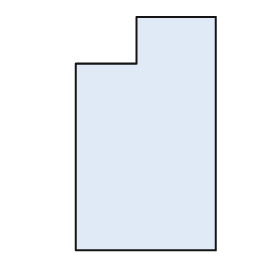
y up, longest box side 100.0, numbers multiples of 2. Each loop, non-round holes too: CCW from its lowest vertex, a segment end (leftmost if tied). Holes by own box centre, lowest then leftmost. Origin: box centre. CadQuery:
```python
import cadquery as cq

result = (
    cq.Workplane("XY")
    .moveTo(-30.0, -50.0)
    .lineTo(30.0, -50.0)
    .lineTo(30.0, 50.0)
    .lineTo(-4.0, 50.0)
    .lineTo(-4.0, 30.0)
    .lineTo(-30.0, 30.0)
    .close()
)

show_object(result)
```